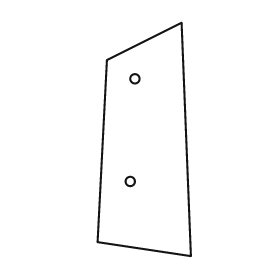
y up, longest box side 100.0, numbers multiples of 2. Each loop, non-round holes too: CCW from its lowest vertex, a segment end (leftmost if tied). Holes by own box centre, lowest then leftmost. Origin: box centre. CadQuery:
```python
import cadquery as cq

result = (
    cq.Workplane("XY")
    .moveTo(20.0, -50.0)
    .lineTo(16.0, 50.0)
    .lineTo(-16.0, 34.0)
    .lineTo(-20.0, -44.0)
    .close()
    .moveTo(-6.0, -18.0)
    .circle(2.0)
    .moveTo(-4.0, 26.0)
    .circle(2.0)
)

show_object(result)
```